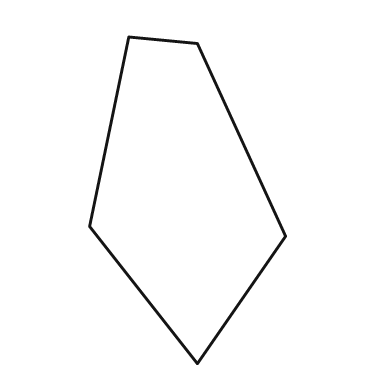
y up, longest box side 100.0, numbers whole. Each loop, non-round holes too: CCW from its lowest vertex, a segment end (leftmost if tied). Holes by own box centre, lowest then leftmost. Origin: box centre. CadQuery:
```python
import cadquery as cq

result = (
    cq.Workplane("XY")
    .moveTo(3.0, -50.0)
    .lineTo(30.0, -11.0)
    .lineTo(3.0, 48.0)
    .lineTo(-18.0, 50.0)
    .lineTo(-30.0, -8.0)
    .close()
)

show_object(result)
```